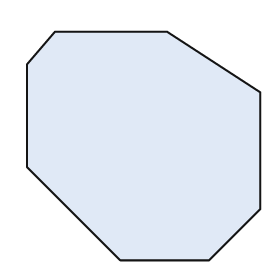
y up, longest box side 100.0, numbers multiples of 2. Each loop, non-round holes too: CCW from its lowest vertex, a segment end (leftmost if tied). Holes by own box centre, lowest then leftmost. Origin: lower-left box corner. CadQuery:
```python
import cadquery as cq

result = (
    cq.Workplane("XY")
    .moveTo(40.0, 0.0)
    .lineTo(78.0, 0.0)
    .lineTo(100.0, 22.0)
    .lineTo(100.0, 72.0)
    .lineTo(60.0, 98.0)
    .lineTo(12.0, 98.0)
    .lineTo(0.0, 84.0)
    .lineTo(0.0, 40.0)
    .close()
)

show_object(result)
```